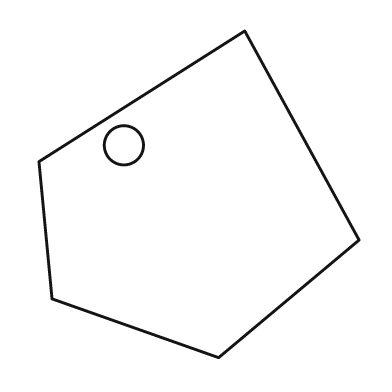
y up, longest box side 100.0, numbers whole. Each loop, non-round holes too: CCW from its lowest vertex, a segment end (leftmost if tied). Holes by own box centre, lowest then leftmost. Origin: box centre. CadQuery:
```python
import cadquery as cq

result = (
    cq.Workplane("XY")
    .moveTo(6.0, -50.0)
    .lineTo(49.0, -14.0)
    .lineTo(14.0, 50.0)
    .lineTo(-49.0, 10.0)
    .lineTo(-45.0, -32.0)
    .close()
    .moveTo(-23.0, 15.0)
    .circle(6.0)
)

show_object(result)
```